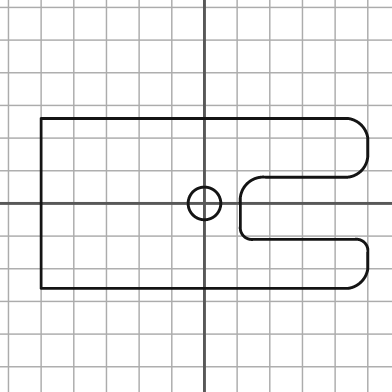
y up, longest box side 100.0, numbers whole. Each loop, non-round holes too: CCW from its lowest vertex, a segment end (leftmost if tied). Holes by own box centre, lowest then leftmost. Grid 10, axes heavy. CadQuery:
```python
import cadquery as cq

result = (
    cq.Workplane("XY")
    .moveTo(-50.0, -26.0)
    .lineTo(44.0, -26.0)
    .threePointArc((48.0, -24.0), (50.0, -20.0))
    .lineTo(50.0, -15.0)
    .threePointArc((49.0, -12.0), (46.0, -11.0))
    .lineTo(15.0, -11.0)
    .threePointArc((12.0, -10.0), (11.0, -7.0))
    .lineTo(11.0, 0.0)
    .threePointArc((13.0, 6.0), (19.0, 8.0))
    .lineTo(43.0, 8.0)
    .threePointArc((48.0, 10.0), (50.0, 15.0))
    .lineTo(50.0, 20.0)
    .threePointArc((48.0, 24.0), (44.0, 26.0))
    .lineTo(-50.0, 26.0)
    .close()
    .moveTo(0.0, 0.0)
    .circle(5.0)
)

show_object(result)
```